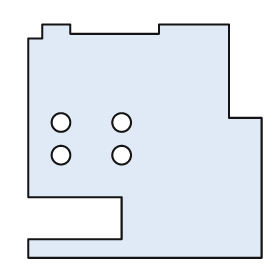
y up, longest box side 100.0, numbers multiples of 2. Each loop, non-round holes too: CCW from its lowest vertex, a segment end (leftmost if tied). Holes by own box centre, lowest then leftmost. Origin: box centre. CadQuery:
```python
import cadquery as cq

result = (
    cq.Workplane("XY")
    .moveTo(-50.0, -50.0)
    .lineTo(50.0, -50.0)
    .lineTo(50.0, 10.0)
    .lineTo(36.0, 10.0)
    .lineTo(36.0, 50.0)
    .lineTo(6.0, 50.0)
    .lineTo(6.0, 46.0)
    .lineTo(-32.0, 46.0)
    .lineTo(-32.0, 50.0)
    .lineTo(-44.0, 50.0)
    .lineTo(-44.0, 44.0)
    .lineTo(-50.0, 44.0)
    .lineTo(-50.0, -24.0)
    .lineTo(-10.0, -24.0)
    .lineTo(-10.0, -42.0)
    .lineTo(-50.0, -42.0)
    .close()
    .moveTo(-36.0, -6.0)
    .circle(4.0)
    .moveTo(-10.0, -6.0)
    .circle(4.0)
    .moveTo(-36.0, 8.0)
    .circle(4.0)
    .moveTo(-10.0, 8.0)
    .circle(4.0)
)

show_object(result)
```